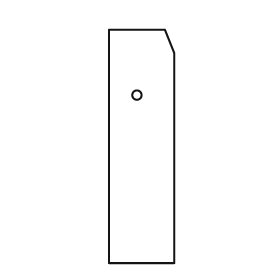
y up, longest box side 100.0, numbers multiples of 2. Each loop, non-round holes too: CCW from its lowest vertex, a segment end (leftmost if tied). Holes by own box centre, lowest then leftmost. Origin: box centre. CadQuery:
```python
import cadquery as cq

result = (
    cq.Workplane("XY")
    .moveTo(-14.0, -50.0)
    .lineTo(14.0, -50.0)
    .lineTo(14.0, 40.0)
    .lineTo(10.0, 50.0)
    .lineTo(-14.0, 50.0)
    .close()
    .moveTo(-2.0, 22.0)
    .circle(2.0)
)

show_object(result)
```